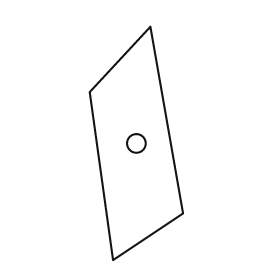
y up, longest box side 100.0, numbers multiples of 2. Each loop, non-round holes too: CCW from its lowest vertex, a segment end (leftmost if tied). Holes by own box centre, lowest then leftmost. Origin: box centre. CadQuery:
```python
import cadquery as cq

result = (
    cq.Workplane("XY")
    .moveTo(-10.0, -50.0)
    .lineTo(20.0, -30.0)
    .lineTo(6.0, 50.0)
    .lineTo(-20.0, 22.0)
    .close()
    .moveTo(0.0, 0.0)
    .circle(4.0)
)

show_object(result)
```